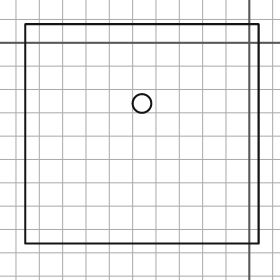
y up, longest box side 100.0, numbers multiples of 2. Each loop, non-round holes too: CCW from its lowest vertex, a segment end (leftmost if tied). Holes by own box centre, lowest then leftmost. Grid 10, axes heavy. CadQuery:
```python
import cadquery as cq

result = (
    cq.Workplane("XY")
    .moveTo(-96.0, -86.0)
    .lineTo(4.0, -86.0)
    .lineTo(4.0, 8.0)
    .lineTo(-96.0, 8.0)
    .close()
    .moveTo(-46.0, -26.0)
    .circle(4.0)
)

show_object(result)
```